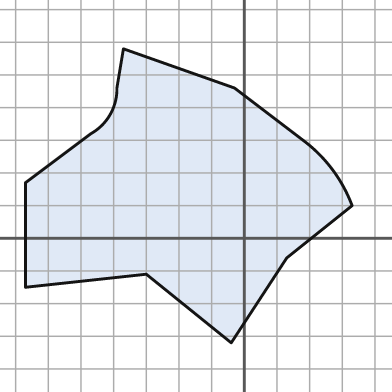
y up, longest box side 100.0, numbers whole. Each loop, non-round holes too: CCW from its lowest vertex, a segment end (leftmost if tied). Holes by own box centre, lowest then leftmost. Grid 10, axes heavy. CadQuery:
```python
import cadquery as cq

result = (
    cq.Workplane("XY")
    .moveTo(-4.0, -32.0)
    .lineTo(13.0, -6.0)
    .lineTo(33.0, 10.0)
    .threePointArc((27.0, 21.0), (18.0, 30.0))
    .lineTo(-3.0, 46.0)
    .lineTo(-37.0, 58.0)
    .lineTo(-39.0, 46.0)
    .threePointArc((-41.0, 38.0), (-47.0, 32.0))
    .lineTo(-67.0, 17.0)
    .lineTo(-67.0, -15.0)
    .lineTo(-30.0, -11.0)
    .close()
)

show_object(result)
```